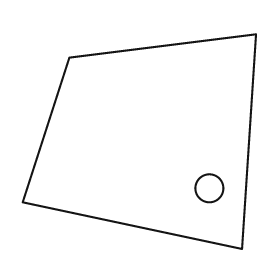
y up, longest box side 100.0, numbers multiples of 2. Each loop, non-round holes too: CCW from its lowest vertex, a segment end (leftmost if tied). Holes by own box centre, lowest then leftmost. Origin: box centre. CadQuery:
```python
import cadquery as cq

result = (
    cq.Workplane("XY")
    .moveTo(44.0, -46.0)
    .lineTo(50.0, 46.0)
    .lineTo(-30.0, 36.0)
    .lineTo(-50.0, -26.0)
    .close()
    .moveTo(30.0, -20.0)
    .circle(6.0)
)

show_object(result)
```